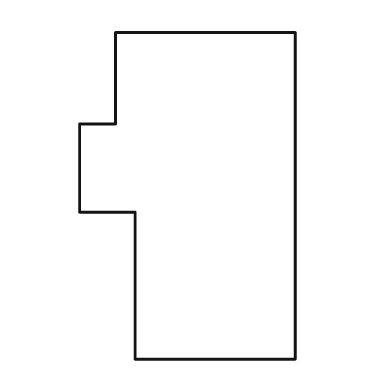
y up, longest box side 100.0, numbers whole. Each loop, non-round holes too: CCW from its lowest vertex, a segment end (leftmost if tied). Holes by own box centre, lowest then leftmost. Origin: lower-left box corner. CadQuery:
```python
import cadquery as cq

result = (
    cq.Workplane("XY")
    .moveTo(17.0, 0.0)
    .lineTo(66.0, 0.0)
    .lineTo(66.0, 100.0)
    .lineTo(11.0, 100.0)
    .lineTo(11.0, 72.0)
    .lineTo(0.0, 72.0)
    .lineTo(0.0, 45.0)
    .lineTo(17.0, 45.0)
    .close()
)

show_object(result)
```